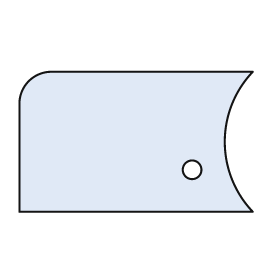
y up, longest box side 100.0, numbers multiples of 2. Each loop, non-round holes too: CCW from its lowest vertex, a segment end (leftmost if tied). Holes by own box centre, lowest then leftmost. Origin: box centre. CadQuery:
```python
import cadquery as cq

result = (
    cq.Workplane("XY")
    .moveTo(-50.0, -30.0)
    .lineTo(50.0, -30.0)
    .threePointArc((38.0, 0.0), (50.0, 30.0))
    .lineTo(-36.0, 30.0)
    .threePointArc((-46.0, 26.0), (-50.0, 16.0))
    .close()
    .moveTo(24.0, -12.0)
    .circle(4.0)
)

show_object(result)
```